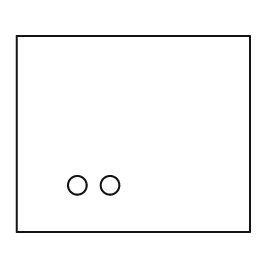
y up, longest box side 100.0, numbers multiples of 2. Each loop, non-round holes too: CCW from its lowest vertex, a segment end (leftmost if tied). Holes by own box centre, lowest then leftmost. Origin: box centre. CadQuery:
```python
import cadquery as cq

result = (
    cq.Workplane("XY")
    .moveTo(-50.0, -42.0)
    .lineTo(50.0, -42.0)
    .lineTo(50.0, 42.0)
    .lineTo(-50.0, 42.0)
    .close()
    .moveTo(-24.0, -22.0)
    .circle(4.0)
    .moveTo(-10.0, -22.0)
    .circle(4.0)
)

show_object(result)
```